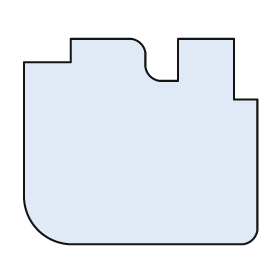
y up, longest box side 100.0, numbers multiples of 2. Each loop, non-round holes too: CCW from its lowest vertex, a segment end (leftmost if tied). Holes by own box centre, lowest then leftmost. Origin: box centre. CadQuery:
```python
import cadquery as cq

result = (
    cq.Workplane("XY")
    .moveTo(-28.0, -44.0)
    .lineTo(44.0, -44.0)
    .threePointArc((48.0, -42.0), (50.0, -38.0))
    .lineTo(50.0, 18.0)
    .lineTo(40.0, 18.0)
    .lineTo(40.0, 44.0)
    .lineTo(16.0, 44.0)
    .lineTo(16.0, 26.0)
    .lineTo(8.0, 26.0)
    .threePointArc((4.0, 28.0), (2.0, 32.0))
    .lineTo(2.0, 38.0)
    .threePointArc((0.0, 42.0), (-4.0, 44.0))
    .lineTo(-30.0, 44.0)
    .lineTo(-30.0, 34.0)
    .lineTo(-50.0, 34.0)
    .lineTo(-50.0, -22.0)
    .threePointArc((-44.0, -38.0), (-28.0, -44.0))
    .close()
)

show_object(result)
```